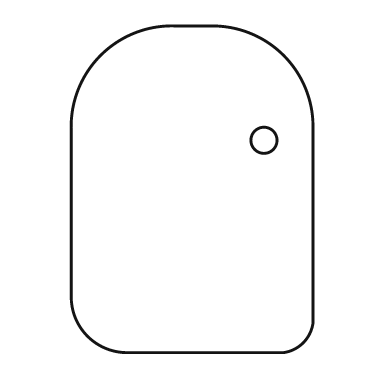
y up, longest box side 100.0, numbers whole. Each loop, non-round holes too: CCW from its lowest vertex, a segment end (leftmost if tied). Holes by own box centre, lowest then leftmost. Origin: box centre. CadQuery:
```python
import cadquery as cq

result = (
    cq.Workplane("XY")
    .moveTo(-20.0, -50.0)
    .lineTo(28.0, -50.0)
    .threePointArc((34.0, -47.0), (37.0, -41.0))
    .lineTo(37.0, 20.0)
    .threePointArc((28.0, 41.0), (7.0, 50.0))
    .lineTo(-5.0, 50.0)
    .threePointArc((-28.0, 41.0), (-37.0, 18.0))
    .lineTo(-37.0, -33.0)
    .threePointArc((-32.0, -45.0), (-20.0, -50.0))
    .close()
    .moveTo(22.0, 15.0)
    .circle(4.0)
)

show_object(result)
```